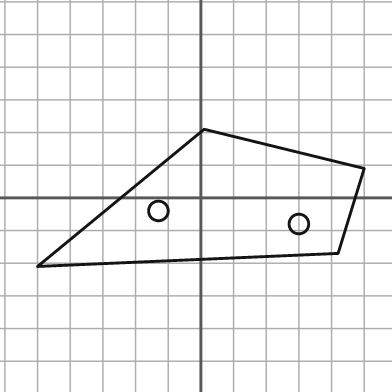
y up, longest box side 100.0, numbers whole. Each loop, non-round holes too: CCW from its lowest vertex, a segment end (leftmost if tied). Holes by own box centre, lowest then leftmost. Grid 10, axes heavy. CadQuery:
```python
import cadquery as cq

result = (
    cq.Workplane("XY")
    .moveTo(-50.0, -21.0)
    .lineTo(42.0, -17.0)
    .lineTo(50.0, 9.0)
    .lineTo(1.0, 21.0)
    .close()
    .moveTo(30.0, -8.0)
    .circle(3.0)
    .moveTo(-13.0, -4.0)
    .circle(3.0)
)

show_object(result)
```